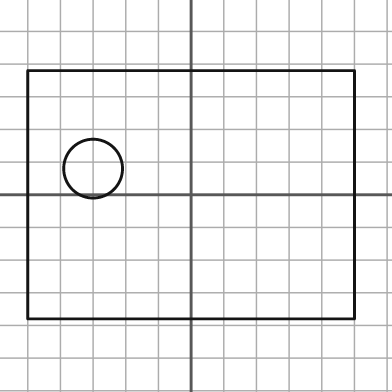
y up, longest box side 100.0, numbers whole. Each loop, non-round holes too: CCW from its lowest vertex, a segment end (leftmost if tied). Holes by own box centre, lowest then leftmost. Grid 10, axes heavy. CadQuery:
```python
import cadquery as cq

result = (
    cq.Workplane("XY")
    .moveTo(-50.0, -38.0)
    .lineTo(50.0, -38.0)
    .lineTo(50.0, 38.0)
    .lineTo(-50.0, 38.0)
    .close()
    .moveTo(-30.0, 8.0)
    .circle(9.0)
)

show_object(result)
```